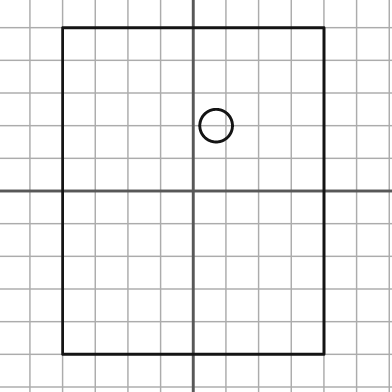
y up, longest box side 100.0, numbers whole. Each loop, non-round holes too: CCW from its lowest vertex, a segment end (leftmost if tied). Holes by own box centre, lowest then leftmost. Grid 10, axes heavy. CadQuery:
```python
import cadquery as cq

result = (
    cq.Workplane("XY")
    .moveTo(-40.0, -50.0)
    .lineTo(40.0, -50.0)
    .lineTo(40.0, 50.0)
    .lineTo(-40.0, 50.0)
    .close()
    .moveTo(7.0, 20.0)
    .circle(5.0)
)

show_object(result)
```